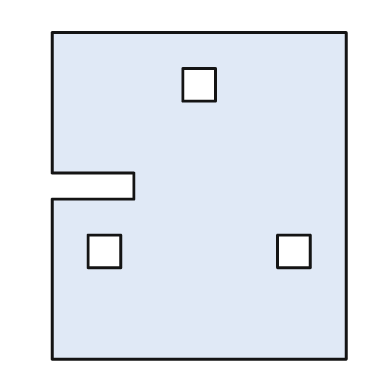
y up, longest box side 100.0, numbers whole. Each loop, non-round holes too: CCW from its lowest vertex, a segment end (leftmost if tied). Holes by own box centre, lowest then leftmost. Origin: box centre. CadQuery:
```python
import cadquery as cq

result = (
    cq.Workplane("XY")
    .moveTo(-45.0, -50.0)
    .lineTo(45.0, -50.0)
    .lineTo(45.0, 50.0)
    .lineTo(-45.0, 50.0)
    .lineTo(-45.0, 7.0)
    .lineTo(-20.0, 7.0)
    .lineTo(-20.0, -1.0)
    .lineTo(-45.0, -1.0)
    .close()
    .moveTo(-34.0, -22.0)
    .lineTo(-24.0, -22.0)
    .lineTo(-24.0, -12.0)
    .lineTo(-34.0, -12.0)
    .close()
    .moveTo(24.0, -22.0)
    .lineTo(34.0, -22.0)
    .lineTo(34.0, -12.0)
    .lineTo(24.0, -12.0)
    .close()
    .moveTo(-5.0, 29.0)
    .lineTo(5.0, 29.0)
    .lineTo(5.0, 39.0)
    .lineTo(-5.0, 39.0)
    .close()
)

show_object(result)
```